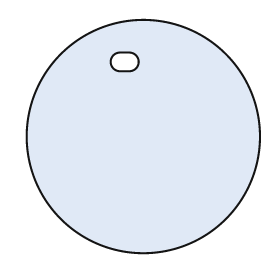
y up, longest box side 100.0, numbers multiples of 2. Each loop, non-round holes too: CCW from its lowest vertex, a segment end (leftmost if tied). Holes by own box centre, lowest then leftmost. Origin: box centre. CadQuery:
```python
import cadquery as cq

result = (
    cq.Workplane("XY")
    .moveTo(0.0, 0.0)
    .circle(50.0)
    .moveTo(-10.0, 28.0)
    .lineTo(-6.0, 28.0)
    .threePointArc((-2.0, 32.0), (-6.0, 36.0))
    .lineTo(-10.0, 36.0)
    .threePointArc((-14.0, 32.0), (-10.0, 28.0))
    .close()
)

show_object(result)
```